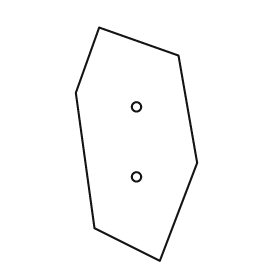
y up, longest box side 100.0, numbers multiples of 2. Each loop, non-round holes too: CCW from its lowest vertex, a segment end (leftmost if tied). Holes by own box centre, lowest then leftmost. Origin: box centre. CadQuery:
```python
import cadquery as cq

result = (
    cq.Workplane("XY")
    .moveTo(10.0, -50.0)
    .lineTo(26.0, -8.0)
    .lineTo(18.0, 38.0)
    .lineTo(-16.0, 50.0)
    .lineTo(-26.0, 22.0)
    .lineTo(-18.0, -36.0)
    .close()
    .moveTo(0.0, -14.0)
    .circle(2.0)
    .moveTo(0.0, 16.0)
    .circle(2.0)
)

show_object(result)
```